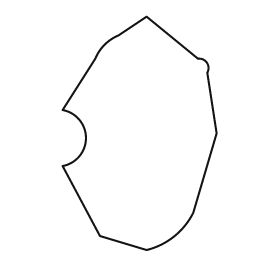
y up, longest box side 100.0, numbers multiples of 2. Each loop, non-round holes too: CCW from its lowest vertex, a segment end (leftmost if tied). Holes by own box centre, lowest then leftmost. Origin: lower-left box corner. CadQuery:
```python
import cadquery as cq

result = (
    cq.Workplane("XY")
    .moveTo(36.0, 0.0)
    .threePointArc((48.0, 6.0), (56.0, 16.0))
    .lineTo(66.0, 50.0)
    .lineTo(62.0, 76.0)
    .threePointArc((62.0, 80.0), (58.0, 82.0))
    .lineTo(36.0, 100.0)
    .lineTo(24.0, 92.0)
    .threePointArc((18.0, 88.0), (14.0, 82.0))
    .lineTo(0.0, 60.0)
    .threePointArc((10.0, 48.0), (0.0, 36.0))
    .lineTo(16.0, 6.0)
    .close()
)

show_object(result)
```